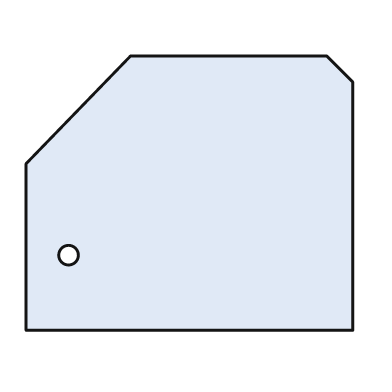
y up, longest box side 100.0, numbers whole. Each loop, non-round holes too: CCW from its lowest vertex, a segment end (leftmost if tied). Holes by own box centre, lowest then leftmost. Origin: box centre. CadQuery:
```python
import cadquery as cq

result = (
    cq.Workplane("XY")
    .moveTo(-50.0, -42.0)
    .lineTo(50.0, -42.0)
    .lineTo(50.0, 34.0)
    .lineTo(42.0, 42.0)
    .lineTo(-18.0, 42.0)
    .lineTo(-50.0, 9.0)
    .close()
    .moveTo(-37.0, -19.0)
    .circle(3.0)
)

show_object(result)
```